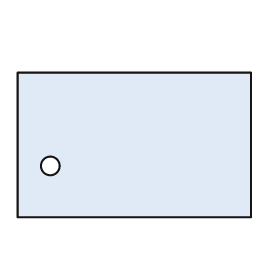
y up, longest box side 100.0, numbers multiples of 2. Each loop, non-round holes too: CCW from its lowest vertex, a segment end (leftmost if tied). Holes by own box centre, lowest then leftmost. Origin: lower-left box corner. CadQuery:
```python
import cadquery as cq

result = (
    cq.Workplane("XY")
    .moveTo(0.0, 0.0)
    .lineTo(100.0, 0.0)
    .lineTo(100.0, 62.0)
    .lineTo(0.0, 62.0)
    .close()
    .moveTo(14.0, 22.0)
    .circle(4.0)
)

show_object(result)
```